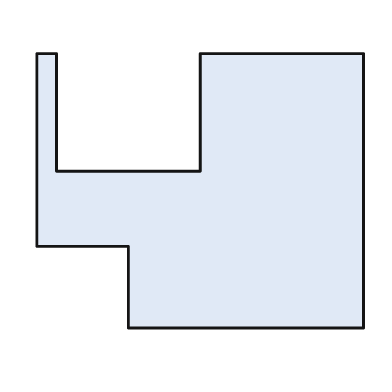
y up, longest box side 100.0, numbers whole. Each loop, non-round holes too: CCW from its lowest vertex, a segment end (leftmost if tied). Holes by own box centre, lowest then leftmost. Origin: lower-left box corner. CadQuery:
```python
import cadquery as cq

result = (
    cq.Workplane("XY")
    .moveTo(28.0, 0.0)
    .lineTo(100.0, 0.0)
    .lineTo(100.0, 84.0)
    .lineTo(50.0, 84.0)
    .lineTo(50.0, 48.0)
    .lineTo(6.0, 48.0)
    .lineTo(6.0, 84.0)
    .lineTo(0.0, 84.0)
    .lineTo(0.0, 25.0)
    .lineTo(28.0, 25.0)
    .close()
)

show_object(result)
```